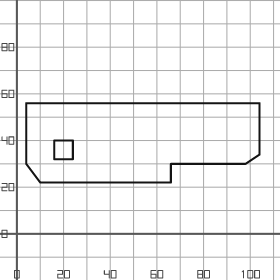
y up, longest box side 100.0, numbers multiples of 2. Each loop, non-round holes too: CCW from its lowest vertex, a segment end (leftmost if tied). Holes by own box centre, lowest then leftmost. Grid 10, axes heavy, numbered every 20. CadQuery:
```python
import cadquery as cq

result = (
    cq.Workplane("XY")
    .moveTo(10.0, 22.0)
    .lineTo(66.0, 22.0)
    .lineTo(66.0, 30.0)
    .lineTo(98.0, 30.0)
    .lineTo(104.0, 34.0)
    .lineTo(104.0, 56.0)
    .lineTo(4.0, 56.0)
    .lineTo(4.0, 30.0)
    .close()
    .moveTo(16.0, 32.0)
    .lineTo(24.0, 32.0)
    .lineTo(24.0, 40.0)
    .lineTo(16.0, 40.0)
    .close()
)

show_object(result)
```